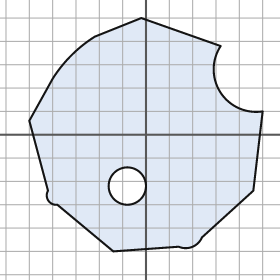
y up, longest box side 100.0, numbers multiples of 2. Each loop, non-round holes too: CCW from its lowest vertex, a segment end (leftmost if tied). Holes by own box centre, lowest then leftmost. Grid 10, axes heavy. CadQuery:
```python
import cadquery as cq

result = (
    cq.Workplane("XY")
    .moveTo(-14.0, -50.0)
    .lineTo(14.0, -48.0)
    .threePointArc((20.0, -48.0), (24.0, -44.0))
    .lineTo(46.0, -24.0)
    .lineTo(50.0, 10.0)
    .threePointArc((32.0, 18.0), (32.0, 38.0))
    .lineTo(-2.0, 50.0)
    .lineTo(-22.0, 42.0)
    .threePointArc((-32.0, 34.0), (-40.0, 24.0))
    .lineTo(-50.0, 6.0)
    .lineTo(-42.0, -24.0)
    .threePointArc((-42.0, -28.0), (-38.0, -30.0))
    .close()
    .moveTo(-8.0, -22.0)
    .circle(8.0)
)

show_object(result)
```